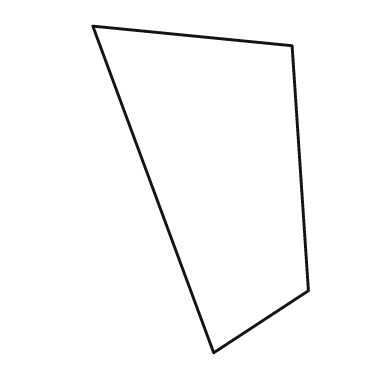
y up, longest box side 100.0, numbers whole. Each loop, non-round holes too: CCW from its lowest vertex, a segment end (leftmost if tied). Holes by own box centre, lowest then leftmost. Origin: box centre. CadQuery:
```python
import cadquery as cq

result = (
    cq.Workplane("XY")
    .moveTo(4.0, -50.0)
    .lineTo(33.0, -31.0)
    .lineTo(28.0, 44.0)
    .lineTo(-33.0, 50.0)
    .close()
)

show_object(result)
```